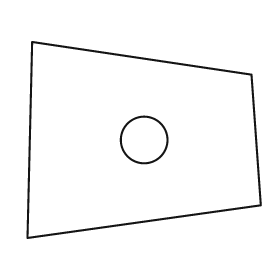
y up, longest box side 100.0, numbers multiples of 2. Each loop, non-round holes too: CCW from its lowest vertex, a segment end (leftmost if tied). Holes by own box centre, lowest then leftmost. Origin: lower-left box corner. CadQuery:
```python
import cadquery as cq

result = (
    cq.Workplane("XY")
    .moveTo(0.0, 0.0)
    .lineTo(100.0, 14.0)
    .lineTo(96.0, 70.0)
    .lineTo(2.0, 84.0)
    .close()
    .moveTo(50.0, 42.0)
    .circle(10.0)
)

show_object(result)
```